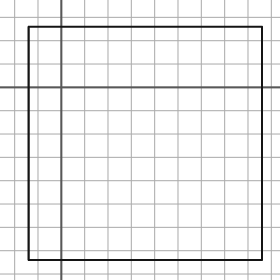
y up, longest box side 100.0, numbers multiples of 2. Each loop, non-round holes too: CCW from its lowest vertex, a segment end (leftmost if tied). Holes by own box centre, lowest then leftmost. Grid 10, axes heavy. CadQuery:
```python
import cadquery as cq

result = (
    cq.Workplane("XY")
    .moveTo(-14.0, -74.0)
    .lineTo(86.0, -74.0)
    .lineTo(86.0, 26.0)
    .lineTo(-14.0, 26.0)
    .close()
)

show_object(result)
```